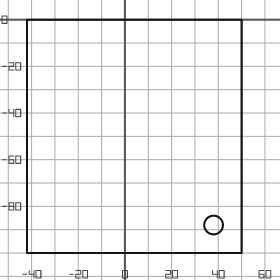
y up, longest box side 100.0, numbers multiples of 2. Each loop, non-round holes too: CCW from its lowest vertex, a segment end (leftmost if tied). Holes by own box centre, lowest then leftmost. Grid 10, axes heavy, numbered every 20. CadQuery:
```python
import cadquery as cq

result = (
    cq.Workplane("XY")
    .moveTo(-42.0, -100.0)
    .lineTo(50.0, -100.0)
    .lineTo(50.0, 0.0)
    .lineTo(-42.0, 0.0)
    .close()
    .moveTo(38.0, -88.0)
    .circle(4.0)
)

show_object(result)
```